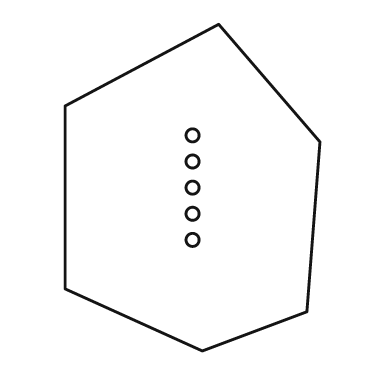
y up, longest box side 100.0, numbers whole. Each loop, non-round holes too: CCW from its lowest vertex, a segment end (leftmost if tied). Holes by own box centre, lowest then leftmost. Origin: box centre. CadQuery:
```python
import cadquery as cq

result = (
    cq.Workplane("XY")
    .moveTo(3.0, -50.0)
    .lineTo(35.0, -38.0)
    .lineTo(39.0, 14.0)
    .lineTo(8.0, 50.0)
    .lineTo(-39.0, 25.0)
    .lineTo(-39.0, -31.0)
    .close()
    .moveTo(0.0, -16.0)
    .circle(2.0)
    .moveTo(0.0, -8.0)
    .circle(2.0)
    .moveTo(0.0, 0.0)
    .circle(2.0)
    .moveTo(0.0, 8.0)
    .circle(2.0)
    .moveTo(0.0, 16.0)
    .circle(2.0)
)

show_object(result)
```